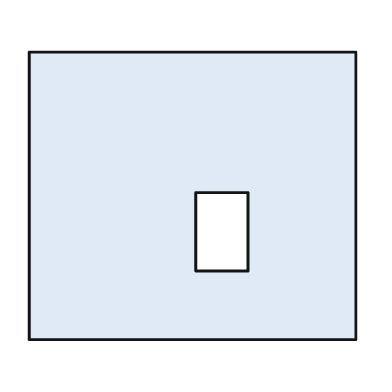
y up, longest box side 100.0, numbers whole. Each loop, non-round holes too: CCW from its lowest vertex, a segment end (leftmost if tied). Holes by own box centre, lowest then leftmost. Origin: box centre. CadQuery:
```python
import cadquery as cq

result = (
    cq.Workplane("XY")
    .moveTo(-50.0, -44.0)
    .lineTo(50.0, -44.0)
    .lineTo(50.0, 44.0)
    .lineTo(-50.0, 44.0)
    .close()
    .moveTo(1.0, -23.0)
    .lineTo(17.0, -23.0)
    .lineTo(17.0, 1.0)
    .lineTo(1.0, 1.0)
    .close()
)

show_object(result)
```